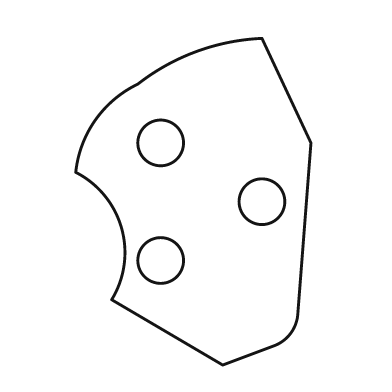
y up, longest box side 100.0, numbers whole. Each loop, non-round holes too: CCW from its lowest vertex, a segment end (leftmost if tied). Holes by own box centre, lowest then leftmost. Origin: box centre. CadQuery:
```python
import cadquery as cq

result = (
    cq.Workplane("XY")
    .moveTo(9.0, -50.0)
    .lineTo(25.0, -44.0)
    .threePointArc((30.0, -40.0), (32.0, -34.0))
    .lineTo(36.0, 18.0)
    .lineTo(21.0, 50.0)
    .threePointArc((1.0, 46.0), (-17.0, 36.0))
    .threePointArc((-30.0, 25.0), (-36.0, 9.0))
    .threePointArc((-22.0, -8.0), (-25.0, -30.0))
    .close()
    .moveTo(-10.0, -18.0)
    .circle(7.0)
    .moveTo(21.0, 0.0)
    .circle(7.0)
    .moveTo(-10.0, 18.0)
    .circle(7.0)
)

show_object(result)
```